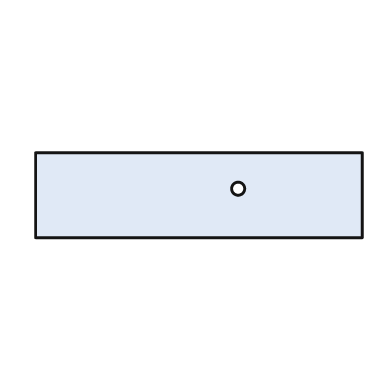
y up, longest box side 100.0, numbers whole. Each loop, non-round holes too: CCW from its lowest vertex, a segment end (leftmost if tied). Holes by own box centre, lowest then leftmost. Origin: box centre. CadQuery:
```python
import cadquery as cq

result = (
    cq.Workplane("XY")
    .moveTo(-50.0, -13.0)
    .lineTo(50.0, -13.0)
    .lineTo(50.0, 13.0)
    .lineTo(-50.0, 13.0)
    .close()
    .moveTo(12.0, 2.0)
    .circle(2.0)
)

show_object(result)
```